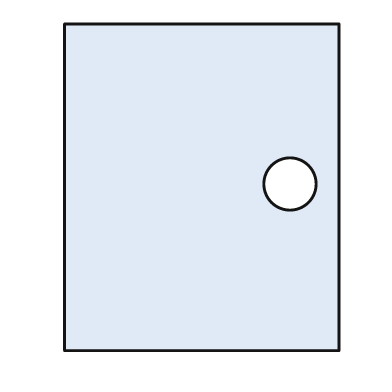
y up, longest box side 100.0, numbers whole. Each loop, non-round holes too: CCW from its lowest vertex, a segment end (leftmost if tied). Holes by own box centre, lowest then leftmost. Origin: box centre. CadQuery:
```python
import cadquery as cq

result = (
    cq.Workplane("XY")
    .moveTo(-42.0, -50.0)
    .lineTo(42.0, -50.0)
    .lineTo(42.0, 50.0)
    .lineTo(-42.0, 50.0)
    .close()
    .moveTo(27.0, 1.0)
    .circle(8.0)
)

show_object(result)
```